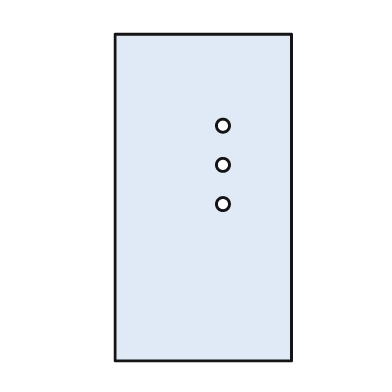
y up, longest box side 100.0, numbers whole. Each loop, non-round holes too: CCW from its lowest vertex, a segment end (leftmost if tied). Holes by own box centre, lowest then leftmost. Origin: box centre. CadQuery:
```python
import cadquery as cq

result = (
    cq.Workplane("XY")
    .moveTo(-27.0, -50.0)
    .lineTo(27.0, -50.0)
    .lineTo(27.0, 50.0)
    .lineTo(-27.0, 50.0)
    .close()
    .moveTo(6.0, -2.0)
    .circle(2.0)
    .moveTo(6.0, 10.0)
    .circle(2.0)
    .moveTo(6.0, 22.0)
    .circle(2.0)
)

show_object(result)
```